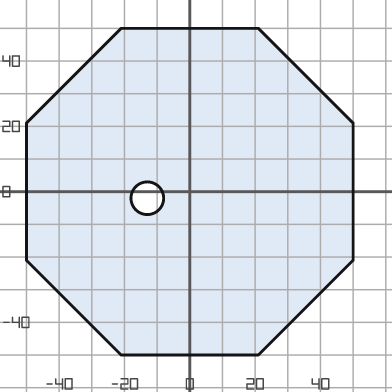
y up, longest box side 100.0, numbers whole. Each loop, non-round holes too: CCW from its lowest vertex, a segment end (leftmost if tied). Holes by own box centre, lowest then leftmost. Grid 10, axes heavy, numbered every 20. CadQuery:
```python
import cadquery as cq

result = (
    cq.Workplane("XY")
    .moveTo(-21.0, -50.0)
    .lineTo(21.0, -50.0)
    .lineTo(50.0, -21.0)
    .lineTo(50.0, 21.0)
    .lineTo(21.0, 50.0)
    .lineTo(-21.0, 50.0)
    .lineTo(-50.0, 21.0)
    .lineTo(-50.0, -21.0)
    .close()
    .moveTo(-13.0, -2.0)
    .circle(5.0)
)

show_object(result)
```